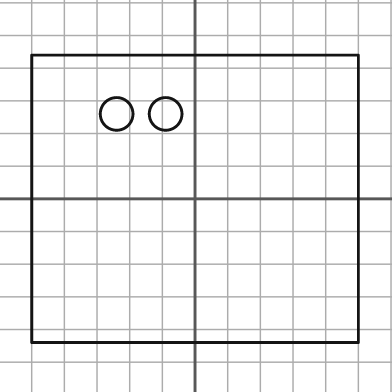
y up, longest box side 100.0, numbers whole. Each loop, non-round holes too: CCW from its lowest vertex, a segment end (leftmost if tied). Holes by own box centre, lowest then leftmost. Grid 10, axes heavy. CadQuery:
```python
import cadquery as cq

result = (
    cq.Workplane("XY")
    .moveTo(-50.0, -44.0)
    .lineTo(50.0, -44.0)
    .lineTo(50.0, 44.0)
    .lineTo(-50.0, 44.0)
    .close()
    .moveTo(-24.0, 26.0)
    .circle(5.0)
    .moveTo(-9.0, 26.0)
    .circle(5.0)
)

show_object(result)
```